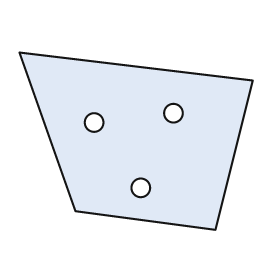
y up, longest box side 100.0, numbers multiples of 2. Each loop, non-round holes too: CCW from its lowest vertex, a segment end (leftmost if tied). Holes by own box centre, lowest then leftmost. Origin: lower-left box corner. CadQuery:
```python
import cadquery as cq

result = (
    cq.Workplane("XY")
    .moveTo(84.0, 0.0)
    .lineTo(100.0, 64.0)
    .lineTo(0.0, 76.0)
    .lineTo(24.0, 8.0)
    .close()
    .moveTo(52.0, 18.0)
    .circle(4.0)
    .moveTo(32.0, 46.0)
    .circle(4.0)
    .moveTo(66.0, 50.0)
    .circle(4.0)
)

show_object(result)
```